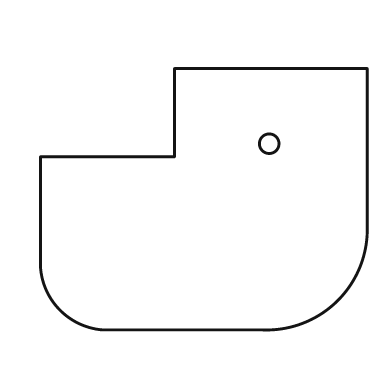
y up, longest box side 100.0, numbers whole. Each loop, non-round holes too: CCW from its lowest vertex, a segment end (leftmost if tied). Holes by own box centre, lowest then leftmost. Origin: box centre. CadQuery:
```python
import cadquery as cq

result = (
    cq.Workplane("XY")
    .moveTo(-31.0, -40.0)
    .lineTo(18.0, -40.0)
    .threePointArc((41.0, -31.0), (50.0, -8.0))
    .lineTo(50.0, 40.0)
    .lineTo(-9.0, 40.0)
    .lineTo(-9.0, 13.0)
    .lineTo(-50.0, 13.0)
    .lineTo(-50.0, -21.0)
    .threePointArc((-44.0, -34.0), (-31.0, -40.0))
    .close()
    .moveTo(20.0, 17.0)
    .circle(3.0)
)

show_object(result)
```